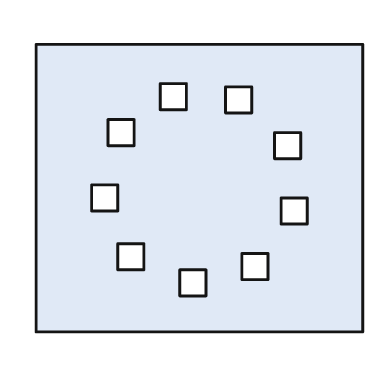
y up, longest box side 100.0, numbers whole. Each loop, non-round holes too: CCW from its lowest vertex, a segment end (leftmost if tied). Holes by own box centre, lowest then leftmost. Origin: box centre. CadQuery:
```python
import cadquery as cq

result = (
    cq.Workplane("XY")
    .moveTo(-50.0, -44.0)
    .lineTo(50.0, -44.0)
    .lineTo(50.0, 44.0)
    .lineTo(-50.0, 44.0)
    .close()
    .moveTo(-6.0, -33.0)
    .lineTo(2.0, -33.0)
    .lineTo(2.0, -25.0)
    .lineTo(-6.0, -25.0)
    .close()
    .moveTo(13.0, -28.0)
    .lineTo(21.0, -28.0)
    .lineTo(21.0, -20.0)
    .lineTo(13.0, -20.0)
    .close()
    .moveTo(-25.0, -25.0)
    .lineTo(-17.0, -25.0)
    .lineTo(-17.0, -17.0)
    .lineTo(-25.0, -17.0)
    .close()
    .moveTo(25.0, -11.0)
    .lineTo(33.0, -11.0)
    .lineTo(33.0, -3.0)
    .lineTo(25.0, -3.0)
    .close()
    .moveTo(-33.0, -7.0)
    .lineTo(-25.0, -7.0)
    .lineTo(-25.0, 1.0)
    .lineTo(-33.0, 1.0)
    .close()
    .moveTo(23.0, 9.0)
    .lineTo(31.0, 9.0)
    .lineTo(31.0, 17.0)
    .lineTo(23.0, 17.0)
    .close()
    .moveTo(-28.0, 13.0)
    .lineTo(-20.0, 13.0)
    .lineTo(-20.0, 21.0)
    .lineTo(-28.0, 21.0)
    .close()
    .moveTo(8.0, 23.0)
    .lineTo(16.0, 23.0)
    .lineTo(16.0, 31.0)
    .lineTo(8.0, 31.0)
    .close()
    .moveTo(-12.0, 24.0)
    .lineTo(-4.0, 24.0)
    .lineTo(-4.0, 32.0)
    .lineTo(-12.0, 32.0)
    .close()
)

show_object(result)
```